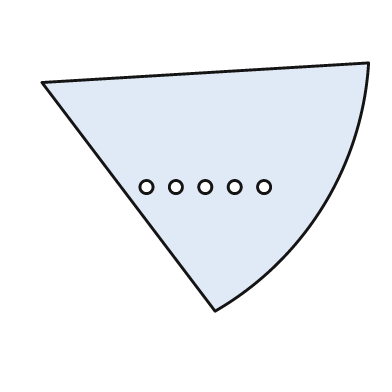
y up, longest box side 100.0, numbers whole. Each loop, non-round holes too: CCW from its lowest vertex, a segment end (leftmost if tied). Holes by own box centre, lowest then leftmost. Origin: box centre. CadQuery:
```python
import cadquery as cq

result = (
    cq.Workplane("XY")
    .moveTo(3.0, -38.0)
    .threePointArc((36.0, -6.0), (50.0, 38.0))
    .lineTo(-50.0, 32.0)
    .close()
    .moveTo(-18.0, 0.0)
    .circle(2.0)
    .moveTo(-9.0, 0.0)
    .circle(2.0)
    .moveTo(0.0, 0.0)
    .circle(2.0)
    .moveTo(9.0, 0.0)
    .circle(2.0)
    .moveTo(18.0, 0.0)
    .circle(2.0)
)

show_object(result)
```